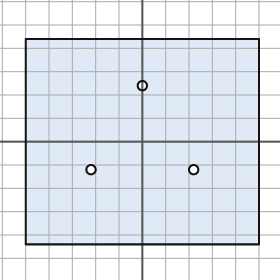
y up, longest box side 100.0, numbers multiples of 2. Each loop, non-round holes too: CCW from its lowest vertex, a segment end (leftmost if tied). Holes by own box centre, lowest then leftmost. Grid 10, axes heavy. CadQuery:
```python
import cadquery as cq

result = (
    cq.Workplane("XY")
    .moveTo(-50.0, -44.0)
    .lineTo(50.0, -44.0)
    .lineTo(50.0, 44.0)
    .lineTo(-50.0, 44.0)
    .close()
    .moveTo(-22.0, -12.0)
    .circle(2.0)
    .moveTo(22.0, -12.0)
    .circle(2.0)
    .moveTo(0.0, 24.0)
    .circle(2.0)
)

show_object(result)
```